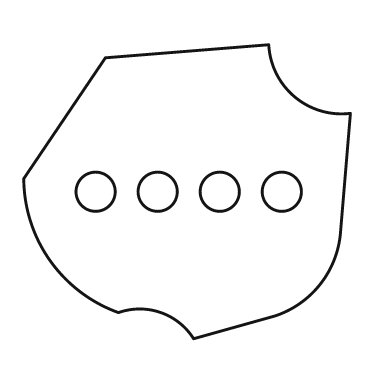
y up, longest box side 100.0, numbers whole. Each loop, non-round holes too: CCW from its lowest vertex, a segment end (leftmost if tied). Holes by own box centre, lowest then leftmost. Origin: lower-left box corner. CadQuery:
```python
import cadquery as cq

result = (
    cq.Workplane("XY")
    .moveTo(52.0, 0.0)
    .lineTo(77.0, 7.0)
    .threePointArc((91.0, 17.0), (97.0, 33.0))
    .lineTo(100.0, 69.0)
    .threePointArc((83.0, 74.0), (75.0, 90.0))
    .lineTo(25.0, 86.0)
    .lineTo(0.0, 49.0)
    .threePointArc((8.0, 24.0), (29.0, 8.0))
    .threePointArc((42.0, 8.0), (52.0, 0.0))
    .close()
    .moveTo(22.0, 45.0)
    .circle(6.0)
    .moveTo(41.0, 45.0)
    .circle(6.0)
    .moveTo(60.0, 45.0)
    .circle(6.0)
    .moveTo(79.0, 45.0)
    .circle(6.0)
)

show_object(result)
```